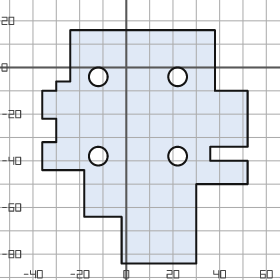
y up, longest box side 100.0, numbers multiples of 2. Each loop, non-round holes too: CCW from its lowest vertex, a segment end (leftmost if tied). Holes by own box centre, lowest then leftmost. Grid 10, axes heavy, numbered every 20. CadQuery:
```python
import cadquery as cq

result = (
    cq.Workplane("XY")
    .moveTo(-2.0, -84.0)
    .lineTo(30.0, -84.0)
    .lineTo(30.0, -50.0)
    .lineTo(52.0, -50.0)
    .lineTo(52.0, -40.0)
    .lineTo(36.0, -40.0)
    .lineTo(36.0, -34.0)
    .lineTo(52.0, -34.0)
    .lineTo(52.0, -10.0)
    .lineTo(38.0, -10.0)
    .lineTo(38.0, 16.0)
    .lineTo(-24.0, 16.0)
    .lineTo(-24.0, -6.0)
    .lineTo(-30.0, -6.0)
    .lineTo(-30.0, -10.0)
    .lineTo(-36.0, -10.0)
    .lineTo(-36.0, -22.0)
    .lineTo(-30.0, -22.0)
    .lineTo(-30.0, -32.0)
    .lineTo(-36.0, -32.0)
    .lineTo(-36.0, -44.0)
    .lineTo(-18.0, -44.0)
    .lineTo(-18.0, -64.0)
    .lineTo(-2.0, -64.0)
    .close()
    .moveTo(-12.0, -38.0)
    .circle(4.0)
    .moveTo(22.0, -38.0)
    .circle(4.0)
    .moveTo(-12.0, -4.0)
    .circle(4.0)
    .moveTo(22.0, -4.0)
    .circle(4.0)
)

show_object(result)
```